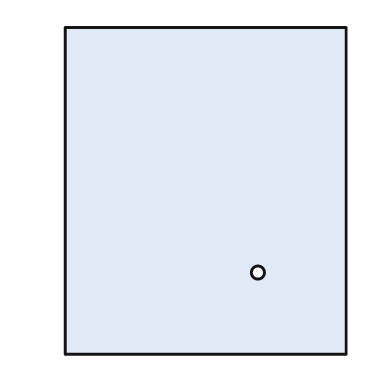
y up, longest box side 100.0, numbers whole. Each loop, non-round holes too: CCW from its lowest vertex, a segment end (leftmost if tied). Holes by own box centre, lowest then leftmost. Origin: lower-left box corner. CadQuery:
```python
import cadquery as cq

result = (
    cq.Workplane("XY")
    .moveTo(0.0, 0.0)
    .lineTo(86.0, 0.0)
    .lineTo(86.0, 100.0)
    .lineTo(0.0, 100.0)
    .close()
    .moveTo(59.0, 25.0)
    .circle(2.0)
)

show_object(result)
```